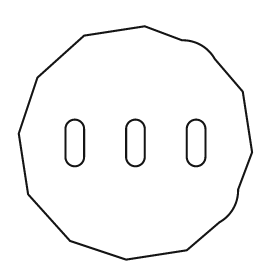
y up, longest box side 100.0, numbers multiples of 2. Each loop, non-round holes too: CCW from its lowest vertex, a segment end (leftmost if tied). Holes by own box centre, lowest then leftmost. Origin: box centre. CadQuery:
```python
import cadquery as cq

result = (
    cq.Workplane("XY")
    .moveTo(-4.0, -50.0)
    .lineTo(22.0, -46.0)
    .lineTo(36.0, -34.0)
    .threePointArc((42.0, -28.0), (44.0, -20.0))
    .lineTo(50.0, -4.0)
    .lineTo(46.0, 22.0)
    .lineTo(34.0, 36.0)
    .threePointArc((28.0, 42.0), (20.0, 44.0))
    .lineTo(4.0, 50.0)
    .lineTo(-22.0, 46.0)
    .lineTo(-42.0, 28.0)
    .lineTo(-50.0, 4.0)
    .lineTo(-46.0, -22.0)
    .lineTo(-28.0, -42.0)
    .close()
    .moveTo(-30.0, -6.0)
    .threePointArc((-26.0, -10.0), (-22.0, -6.0))
    .lineTo(-22.0, 6.0)
    .threePointArc((-26.0, 10.0), (-30.0, 6.0))
    .close()
    .moveTo(-4.0, -6.0)
    .threePointArc((0.0, -10.0), (4.0, -6.0))
    .lineTo(4.0, 6.0)
    .threePointArc((0.0, 10.0), (-4.0, 6.0))
    .close()
    .moveTo(22.0, -6.0)
    .threePointArc((26.0, -10.0), (30.0, -6.0))
    .lineTo(30.0, 6.0)
    .threePointArc((26.0, 10.0), (22.0, 6.0))
    .close()
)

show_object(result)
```